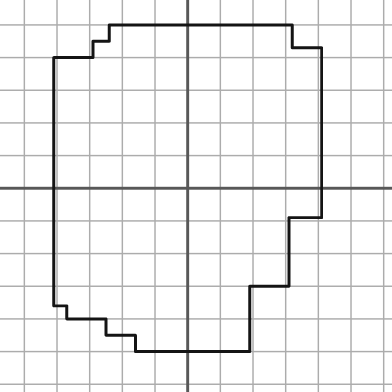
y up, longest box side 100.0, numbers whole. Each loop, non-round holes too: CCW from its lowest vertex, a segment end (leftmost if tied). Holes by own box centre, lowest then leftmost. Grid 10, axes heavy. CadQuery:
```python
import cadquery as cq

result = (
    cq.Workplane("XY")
    .moveTo(-16.0, -50.0)
    .lineTo(19.0, -50.0)
    .lineTo(19.0, -30.0)
    .lineTo(31.0, -30.0)
    .lineTo(31.0, -9.0)
    .lineTo(41.0, -9.0)
    .lineTo(41.0, 43.0)
    .lineTo(32.0, 43.0)
    .lineTo(32.0, 50.0)
    .lineTo(-24.0, 50.0)
    .lineTo(-24.0, 45.0)
    .lineTo(-29.0, 45.0)
    .lineTo(-29.0, 40.0)
    .lineTo(-41.0, 40.0)
    .lineTo(-41.0, -36.0)
    .lineTo(-37.0, -36.0)
    .lineTo(-37.0, -40.0)
    .lineTo(-25.0, -40.0)
    .lineTo(-25.0, -45.0)
    .lineTo(-16.0, -45.0)
    .close()
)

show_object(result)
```